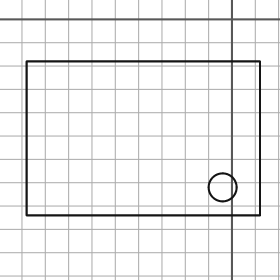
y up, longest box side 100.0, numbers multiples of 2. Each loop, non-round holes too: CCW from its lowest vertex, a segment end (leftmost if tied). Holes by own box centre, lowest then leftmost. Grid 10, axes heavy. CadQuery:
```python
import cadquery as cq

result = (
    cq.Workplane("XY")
    .moveTo(-88.0, -84.0)
    .lineTo(12.0, -84.0)
    .lineTo(12.0, -18.0)
    .lineTo(-88.0, -18.0)
    .close()
    .moveTo(-4.0, -72.0)
    .circle(6.0)
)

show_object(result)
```